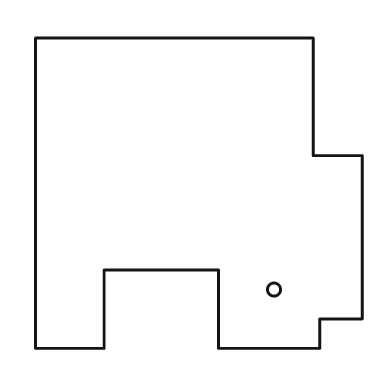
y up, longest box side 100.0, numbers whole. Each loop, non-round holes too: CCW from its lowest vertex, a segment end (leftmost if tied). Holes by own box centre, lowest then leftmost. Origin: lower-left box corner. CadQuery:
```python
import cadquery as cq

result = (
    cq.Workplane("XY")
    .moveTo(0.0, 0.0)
    .lineTo(21.0, 0.0)
    .lineTo(21.0, 24.0)
    .lineTo(56.0, 24.0)
    .lineTo(56.0, 0.0)
    .lineTo(87.0, 0.0)
    .lineTo(87.0, 9.0)
    .lineTo(100.0, 9.0)
    .lineTo(100.0, 59.0)
    .lineTo(85.0, 59.0)
    .lineTo(85.0, 95.0)
    .lineTo(0.0, 95.0)
    .close()
    .moveTo(73.0, 18.0)
    .circle(2.0)
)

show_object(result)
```